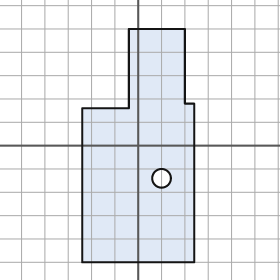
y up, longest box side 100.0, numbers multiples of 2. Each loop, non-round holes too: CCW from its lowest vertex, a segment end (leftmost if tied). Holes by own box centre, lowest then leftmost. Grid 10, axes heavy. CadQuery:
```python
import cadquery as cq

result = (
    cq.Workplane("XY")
    .moveTo(-24.0, -50.0)
    .lineTo(24.0, -50.0)
    .lineTo(24.0, 18.0)
    .lineTo(20.0, 18.0)
    .lineTo(20.0, 50.0)
    .lineTo(-4.0, 50.0)
    .lineTo(-4.0, 16.0)
    .lineTo(-24.0, 16.0)
    .close()
    .moveTo(10.0, -14.0)
    .circle(4.0)
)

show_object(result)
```